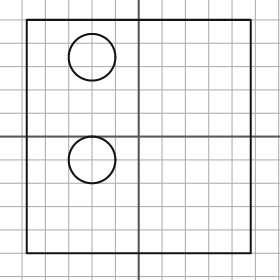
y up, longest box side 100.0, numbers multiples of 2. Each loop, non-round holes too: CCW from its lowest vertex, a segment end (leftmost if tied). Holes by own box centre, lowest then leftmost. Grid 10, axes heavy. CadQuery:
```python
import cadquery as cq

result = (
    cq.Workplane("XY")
    .moveTo(-48.0, -50.0)
    .lineTo(48.0, -50.0)
    .lineTo(48.0, 50.0)
    .lineTo(-48.0, 50.0)
    .close()
    .moveTo(-20.0, -10.0)
    .circle(10.0)
    .moveTo(-20.0, 34.0)
    .circle(10.0)
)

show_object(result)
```